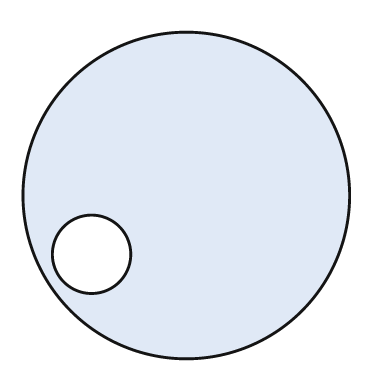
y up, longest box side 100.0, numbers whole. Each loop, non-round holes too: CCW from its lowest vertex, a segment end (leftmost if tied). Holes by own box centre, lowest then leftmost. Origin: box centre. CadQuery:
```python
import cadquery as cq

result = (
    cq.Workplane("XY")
    .moveTo(0.0, 0.0)
    .circle(50.0)
    .moveTo(-29.0, -18.0)
    .circle(12.0)
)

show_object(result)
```